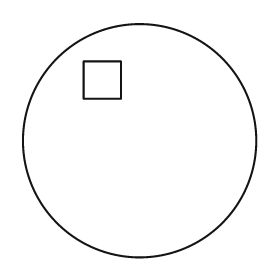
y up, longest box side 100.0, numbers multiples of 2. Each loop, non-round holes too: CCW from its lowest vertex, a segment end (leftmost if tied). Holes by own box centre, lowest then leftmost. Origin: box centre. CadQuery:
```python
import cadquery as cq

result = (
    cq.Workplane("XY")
    .moveTo(0.0, 0.0)
    .circle(50.0)
    .moveTo(-24.0, 18.0)
    .lineTo(-8.0, 18.0)
    .lineTo(-8.0, 34.0)
    .lineTo(-24.0, 34.0)
    .close()
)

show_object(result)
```